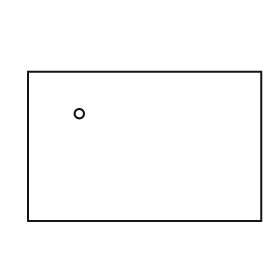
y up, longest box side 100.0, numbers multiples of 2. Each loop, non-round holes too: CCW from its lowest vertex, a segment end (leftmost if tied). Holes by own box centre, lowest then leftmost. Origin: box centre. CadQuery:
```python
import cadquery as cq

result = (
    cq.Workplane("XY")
    .moveTo(-50.0, -32.0)
    .lineTo(50.0, -32.0)
    .lineTo(50.0, 32.0)
    .lineTo(-50.0, 32.0)
    .close()
    .moveTo(-28.0, 14.0)
    .circle(2.0)
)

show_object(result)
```